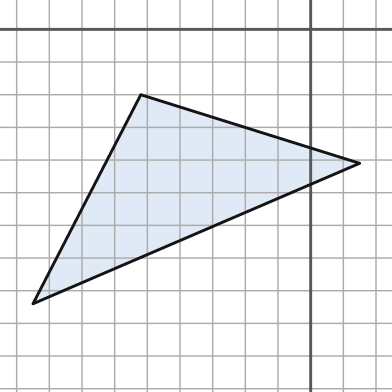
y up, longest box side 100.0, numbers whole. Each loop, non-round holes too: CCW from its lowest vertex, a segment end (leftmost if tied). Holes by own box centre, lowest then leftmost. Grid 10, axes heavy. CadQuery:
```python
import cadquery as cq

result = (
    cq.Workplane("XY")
    .moveTo(-85.0, -84.0)
    .lineTo(15.0, -41.0)
    .lineTo(-52.0, -20.0)
    .close()
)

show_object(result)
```